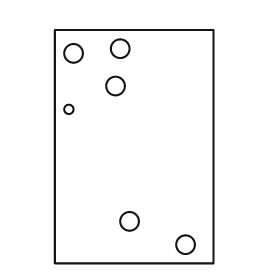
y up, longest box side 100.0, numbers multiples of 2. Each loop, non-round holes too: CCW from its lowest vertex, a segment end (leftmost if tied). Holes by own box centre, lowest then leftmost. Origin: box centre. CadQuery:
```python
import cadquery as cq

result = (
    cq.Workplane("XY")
    .moveTo(-34.0, -50.0)
    .lineTo(34.0, -50.0)
    .lineTo(34.0, 50.0)
    .lineTo(-34.0, 50.0)
    .close()
    .moveTo(22.0, -42.0)
    .circle(4.0)
    .moveTo(-2.0, -32.0)
    .circle(4.0)
    .moveTo(-28.0, 16.0)
    .circle(2.0)
    .moveTo(-8.0, 26.0)
    .circle(4.0)
    .moveTo(-26.0, 40.0)
    .circle(4.0)
    .moveTo(-6.0, 42.0)
    .circle(4.0)
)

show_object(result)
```